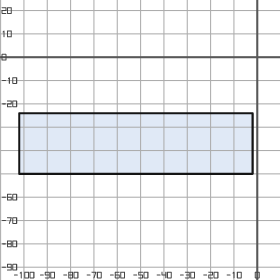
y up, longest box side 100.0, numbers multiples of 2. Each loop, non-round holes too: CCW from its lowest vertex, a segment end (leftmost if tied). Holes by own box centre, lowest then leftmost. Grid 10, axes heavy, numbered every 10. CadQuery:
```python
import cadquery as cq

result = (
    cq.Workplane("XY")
    .moveTo(-102.0, -50.0)
    .lineTo(-2.0, -50.0)
    .lineTo(-2.0, -24.0)
    .lineTo(-102.0, -24.0)
    .close()
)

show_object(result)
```